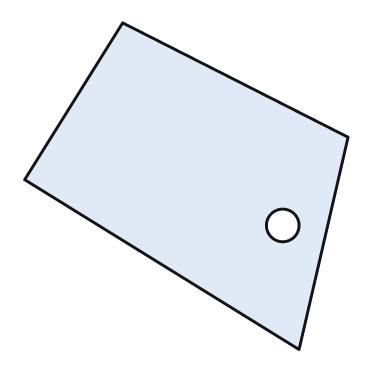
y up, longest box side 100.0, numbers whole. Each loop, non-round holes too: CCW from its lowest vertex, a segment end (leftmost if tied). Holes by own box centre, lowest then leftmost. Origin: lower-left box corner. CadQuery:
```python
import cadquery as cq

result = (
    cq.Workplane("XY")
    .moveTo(84.0, 0.0)
    .lineTo(99.0, 65.0)
    .lineTo(30.0, 100.0)
    .lineTo(0.0, 52.0)
    .close()
    .moveTo(79.0, 38.0)
    .circle(5.0)
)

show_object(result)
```